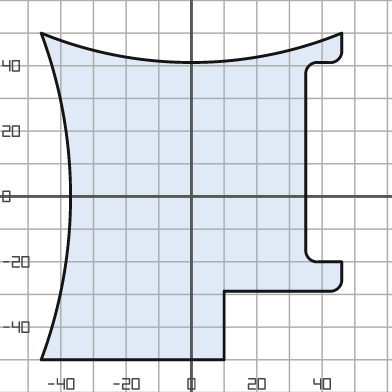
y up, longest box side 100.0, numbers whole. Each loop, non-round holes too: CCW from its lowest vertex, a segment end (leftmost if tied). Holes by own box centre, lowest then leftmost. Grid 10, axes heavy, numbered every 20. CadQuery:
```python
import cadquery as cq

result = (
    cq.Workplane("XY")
    .moveTo(-46.0, -50.0)
    .lineTo(10.0, -50.0)
    .lineTo(10.0, -29.0)
    .lineTo(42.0, -29.0)
    .threePointArc((45.0, -28.0), (46.0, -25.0))
    .lineTo(46.0, -20.0)
    .lineTo(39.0, -20.0)
    .threePointArc((36.0, -19.0), (35.0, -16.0))
    .lineTo(35.0, 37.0)
    .threePointArc((36.0, 40.0), (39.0, 41.0))
    .lineTo(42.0, 41.0)
    .threePointArc((45.0, 42.0), (46.0, 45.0))
    .lineTo(46.0, 50.0)
    .threePointArc((0.0, 41.0), (-46.0, 50.0))
    .threePointArc((-37.0, 0.0), (-46.0, -50.0))
    .close()
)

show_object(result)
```